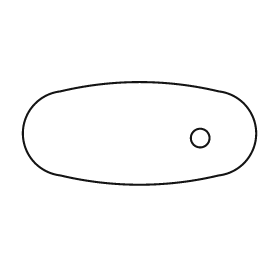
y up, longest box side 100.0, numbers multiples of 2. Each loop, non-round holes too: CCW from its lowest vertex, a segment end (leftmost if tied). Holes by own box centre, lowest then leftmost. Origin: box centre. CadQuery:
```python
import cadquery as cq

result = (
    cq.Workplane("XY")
    .moveTo(-34.0, -18.0)
    .threePointArc((0.0, -22.0), (34.0, -18.0))
    .threePointArc((50.0, 0.0), (34.0, 18.0))
    .threePointArc((0.0, 22.0), (-34.0, 18.0))
    .threePointArc((-50.0, 0.0), (-34.0, -18.0))
    .close()
    .moveTo(26.0, -2.0)
    .circle(4.0)
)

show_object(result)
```